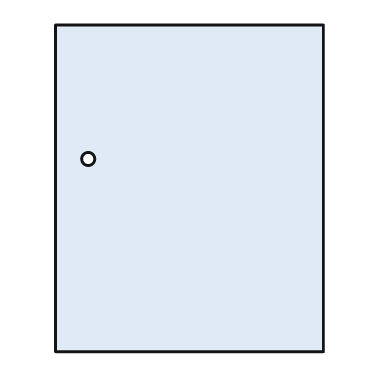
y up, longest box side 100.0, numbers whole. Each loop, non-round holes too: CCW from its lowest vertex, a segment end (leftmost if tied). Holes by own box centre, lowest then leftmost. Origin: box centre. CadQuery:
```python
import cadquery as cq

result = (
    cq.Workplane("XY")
    .moveTo(-41.0, -50.0)
    .lineTo(41.0, -50.0)
    .lineTo(41.0, 50.0)
    .lineTo(-41.0, 50.0)
    .close()
    .moveTo(-31.0, 9.0)
    .circle(2.0)
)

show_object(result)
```